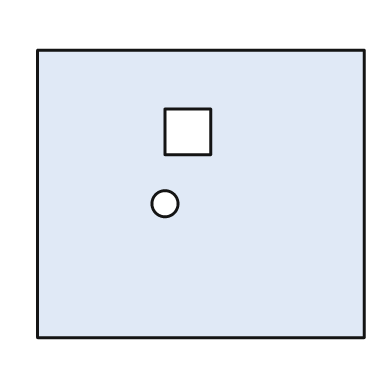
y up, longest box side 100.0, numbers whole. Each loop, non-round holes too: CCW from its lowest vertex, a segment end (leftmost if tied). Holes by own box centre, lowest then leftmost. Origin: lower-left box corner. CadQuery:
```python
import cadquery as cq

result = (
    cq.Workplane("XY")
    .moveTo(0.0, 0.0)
    .lineTo(100.0, 0.0)
    .lineTo(100.0, 88.0)
    .lineTo(0.0, 88.0)
    .close()
    .moveTo(39.0, 41.0)
    .circle(4.0)
    .moveTo(39.0, 56.0)
    .lineTo(53.0, 56.0)
    .lineTo(53.0, 70.0)
    .lineTo(39.0, 70.0)
    .close()
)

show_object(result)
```